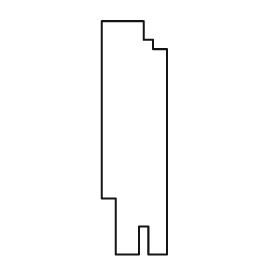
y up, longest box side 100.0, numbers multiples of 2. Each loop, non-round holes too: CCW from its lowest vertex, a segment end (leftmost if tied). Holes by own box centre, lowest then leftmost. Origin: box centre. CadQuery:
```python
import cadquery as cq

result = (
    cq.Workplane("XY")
    .moveTo(-8.0, -50.0)
    .lineTo(2.0, -50.0)
    .lineTo(2.0, -38.0)
    .lineTo(6.0, -38.0)
    .lineTo(6.0, -50.0)
    .lineTo(14.0, -50.0)
    .lineTo(14.0, 38.0)
    .lineTo(8.0, 38.0)
    .lineTo(8.0, 42.0)
    .lineTo(4.0, 42.0)
    .lineTo(4.0, 50.0)
    .lineTo(-14.0, 50.0)
    .lineTo(-14.0, -26.0)
    .lineTo(-8.0, -26.0)
    .close()
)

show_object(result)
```